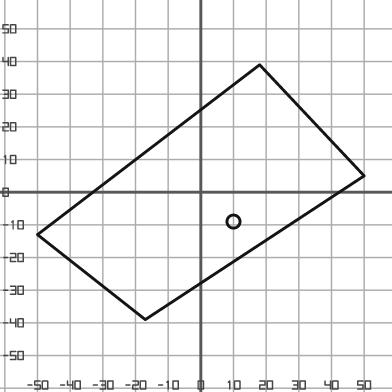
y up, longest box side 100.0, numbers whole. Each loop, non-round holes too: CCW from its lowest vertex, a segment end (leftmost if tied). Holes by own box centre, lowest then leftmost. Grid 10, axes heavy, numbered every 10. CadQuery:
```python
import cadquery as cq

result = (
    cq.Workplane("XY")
    .moveTo(-17.0, -39.0)
    .lineTo(50.0, 5.0)
    .lineTo(18.0, 39.0)
    .lineTo(-50.0, -13.0)
    .close()
    .moveTo(10.0, -9.0)
    .circle(2.0)
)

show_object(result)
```